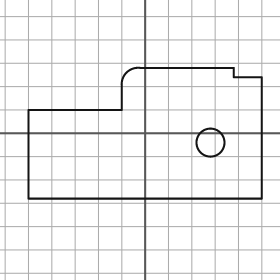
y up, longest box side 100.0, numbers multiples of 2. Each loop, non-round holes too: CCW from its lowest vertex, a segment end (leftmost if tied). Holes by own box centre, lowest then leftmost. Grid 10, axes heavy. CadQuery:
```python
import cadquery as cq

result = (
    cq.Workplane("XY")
    .moveTo(-50.0, -28.0)
    .lineTo(50.0, -28.0)
    .lineTo(50.0, 24.0)
    .lineTo(38.0, 24.0)
    .lineTo(38.0, 28.0)
    .lineTo(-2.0, 28.0)
    .threePointArc((-8.0, 26.0), (-10.0, 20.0))
    .lineTo(-10.0, 10.0)
    .lineTo(-50.0, 10.0)
    .close()
    .moveTo(28.0, -4.0)
    .circle(6.0)
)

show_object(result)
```